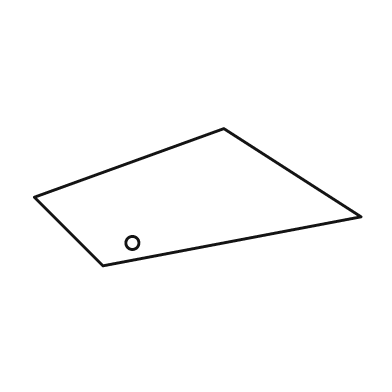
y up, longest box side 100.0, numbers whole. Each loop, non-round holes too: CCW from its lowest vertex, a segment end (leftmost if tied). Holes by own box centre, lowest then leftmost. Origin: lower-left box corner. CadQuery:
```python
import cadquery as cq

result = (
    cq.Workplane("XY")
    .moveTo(21.0, 0.0)
    .lineTo(100.0, 15.0)
    .lineTo(58.0, 42.0)
    .lineTo(0.0, 21.0)
    .close()
    .moveTo(30.0, 7.0)
    .circle(2.0)
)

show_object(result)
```